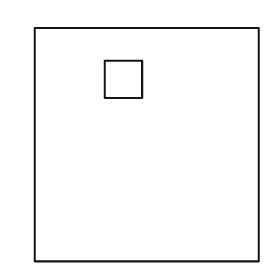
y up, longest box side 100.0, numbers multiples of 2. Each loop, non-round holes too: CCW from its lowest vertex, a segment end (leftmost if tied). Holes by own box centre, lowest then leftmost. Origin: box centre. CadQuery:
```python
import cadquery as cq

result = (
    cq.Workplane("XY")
    .moveTo(-48.0, -50.0)
    .lineTo(48.0, -50.0)
    .lineTo(48.0, 50.0)
    .lineTo(-48.0, 50.0)
    .close()
    .moveTo(-18.0, 20.0)
    .lineTo(-2.0, 20.0)
    .lineTo(-2.0, 36.0)
    .lineTo(-18.0, 36.0)
    .close()
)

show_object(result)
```